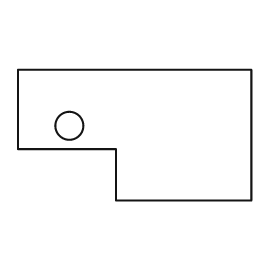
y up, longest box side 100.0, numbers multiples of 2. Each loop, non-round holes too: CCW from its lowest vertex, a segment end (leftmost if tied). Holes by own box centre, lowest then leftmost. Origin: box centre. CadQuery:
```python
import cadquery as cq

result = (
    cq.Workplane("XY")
    .moveTo(-8.0, -28.0)
    .lineTo(50.0, -28.0)
    .lineTo(50.0, 28.0)
    .lineTo(-50.0, 28.0)
    .lineTo(-50.0, -6.0)
    .lineTo(-8.0, -6.0)
    .close()
    .moveTo(-28.0, 4.0)
    .circle(6.0)
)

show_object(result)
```